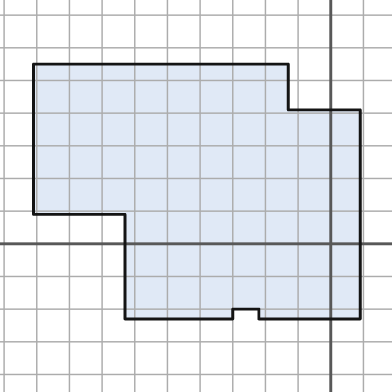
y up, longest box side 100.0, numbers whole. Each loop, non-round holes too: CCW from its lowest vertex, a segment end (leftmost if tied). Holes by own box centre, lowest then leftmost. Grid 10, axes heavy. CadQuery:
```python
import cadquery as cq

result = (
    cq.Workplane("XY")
    .moveTo(-63.0, -23.0)
    .lineTo(-30.0, -23.0)
    .lineTo(-30.0, -20.0)
    .lineTo(-22.0, -20.0)
    .lineTo(-22.0, -23.0)
    .lineTo(9.0, -23.0)
    .lineTo(9.0, 41.0)
    .lineTo(-13.0, 41.0)
    .lineTo(-13.0, 55.0)
    .lineTo(-91.0, 55.0)
    .lineTo(-91.0, 9.0)
    .lineTo(-63.0, 9.0)
    .close()
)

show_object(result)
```